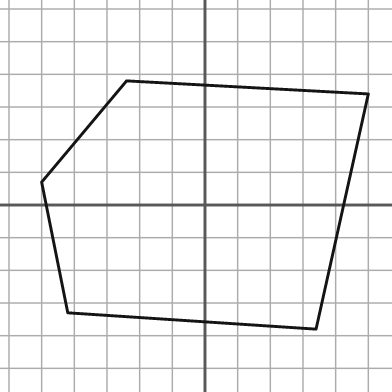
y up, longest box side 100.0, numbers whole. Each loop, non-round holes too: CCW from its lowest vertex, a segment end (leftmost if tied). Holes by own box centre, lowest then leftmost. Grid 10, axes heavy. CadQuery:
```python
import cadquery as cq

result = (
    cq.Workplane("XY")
    .moveTo(34.0, -38.0)
    .lineTo(50.0, 34.0)
    .lineTo(-24.0, 38.0)
    .lineTo(-50.0, 7.0)
    .lineTo(-42.0, -33.0)
    .close()
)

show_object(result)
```